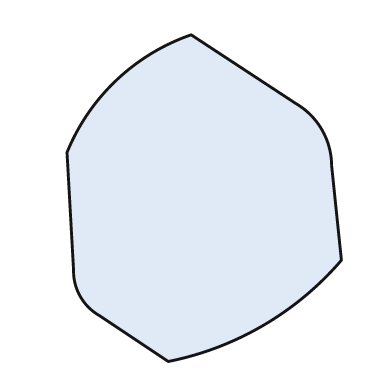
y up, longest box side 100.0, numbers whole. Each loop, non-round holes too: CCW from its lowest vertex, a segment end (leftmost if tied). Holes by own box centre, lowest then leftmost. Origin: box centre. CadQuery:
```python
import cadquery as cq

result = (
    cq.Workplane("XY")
    .moveTo(-11.0, -50.0)
    .threePointArc((18.0, -39.0), (42.0, -19.0))
    .lineTo(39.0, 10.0)
    .threePointArc((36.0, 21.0), (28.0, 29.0))
    .lineTo(-4.0, 50.0)
    .threePointArc((-27.0, 36.0), (-42.0, 14.0))
    .lineTo(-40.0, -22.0)
    .threePointArc((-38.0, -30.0), (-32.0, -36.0))
    .close()
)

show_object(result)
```